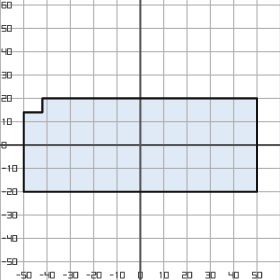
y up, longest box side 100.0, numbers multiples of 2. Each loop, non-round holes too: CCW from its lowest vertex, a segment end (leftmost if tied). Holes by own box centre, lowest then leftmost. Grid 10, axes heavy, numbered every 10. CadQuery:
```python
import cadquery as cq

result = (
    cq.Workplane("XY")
    .moveTo(-50.0, -20.0)
    .lineTo(50.0, -20.0)
    .lineTo(50.0, 20.0)
    .lineTo(-42.0, 20.0)
    .lineTo(-42.0, 14.0)
    .lineTo(-50.0, 14.0)
    .close()
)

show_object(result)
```